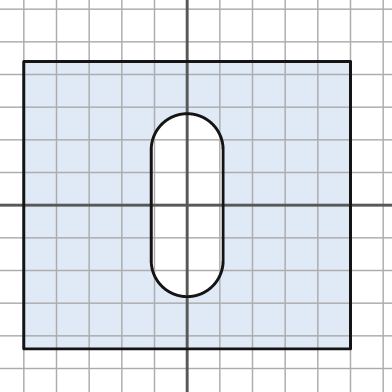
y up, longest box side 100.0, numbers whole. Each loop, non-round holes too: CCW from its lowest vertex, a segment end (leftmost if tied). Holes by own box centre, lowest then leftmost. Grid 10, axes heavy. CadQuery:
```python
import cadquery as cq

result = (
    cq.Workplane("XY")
    .moveTo(-50.0, -44.0)
    .lineTo(50.0, -44.0)
    .lineTo(50.0, 44.0)
    .lineTo(-50.0, 44.0)
    .close()
    .moveTo(-11.0, -17.0)
    .threePointArc((0.0, -28.0), (11.0, -17.0))
    .lineTo(11.0, 17.0)
    .threePointArc((0.0, 28.0), (-11.0, 17.0))
    .close()
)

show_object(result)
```